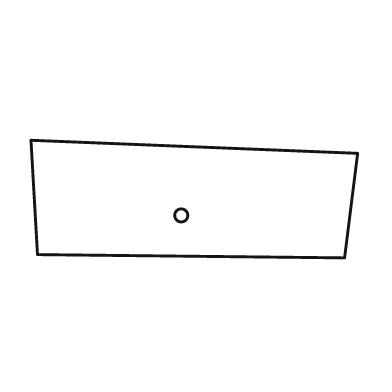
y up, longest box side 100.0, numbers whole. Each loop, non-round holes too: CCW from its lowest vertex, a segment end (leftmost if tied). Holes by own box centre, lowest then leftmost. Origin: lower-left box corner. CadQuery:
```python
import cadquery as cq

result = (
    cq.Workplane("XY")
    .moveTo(96.0, 0.0)
    .lineTo(100.0, 32.0)
    .lineTo(0.0, 36.0)
    .lineTo(2.0, 1.0)
    .close()
    .moveTo(46.0, 13.0)
    .circle(2.0)
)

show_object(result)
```